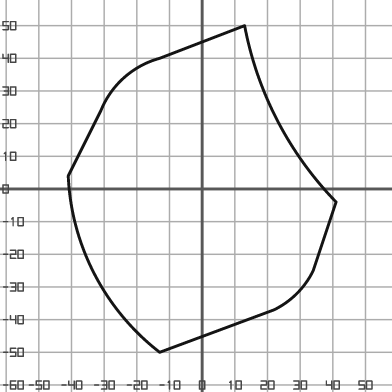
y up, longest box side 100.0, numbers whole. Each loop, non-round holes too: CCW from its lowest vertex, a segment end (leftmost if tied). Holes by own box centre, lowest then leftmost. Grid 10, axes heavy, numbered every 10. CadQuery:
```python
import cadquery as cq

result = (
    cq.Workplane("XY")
    .moveTo(-13.0, -50.0)
    .lineTo(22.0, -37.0)
    .threePointArc((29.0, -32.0), (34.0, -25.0))
    .lineTo(41.0, -4.0)
    .threePointArc((23.0, 21.0), (13.0, 50.0))
    .lineTo(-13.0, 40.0)
    .threePointArc((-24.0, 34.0), (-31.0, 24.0))
    .lineTo(-41.0, 4.0)
    .threePointArc((-33.0, -26.0), (-13.0, -50.0))
    .close()
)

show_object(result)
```